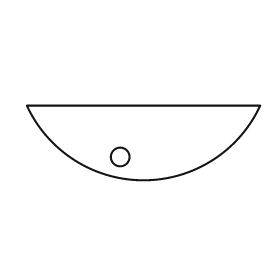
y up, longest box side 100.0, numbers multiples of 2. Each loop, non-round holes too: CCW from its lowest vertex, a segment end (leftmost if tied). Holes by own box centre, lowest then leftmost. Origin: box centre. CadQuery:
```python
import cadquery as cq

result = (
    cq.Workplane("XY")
    .moveTo(-50.0, 16.0)
    .threePointArc((0.0, -16.0), (50.0, 16.0))
    .close()
    .moveTo(-10.0, -6.0)
    .circle(4.0)
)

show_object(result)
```